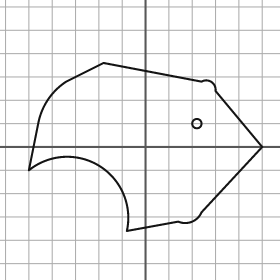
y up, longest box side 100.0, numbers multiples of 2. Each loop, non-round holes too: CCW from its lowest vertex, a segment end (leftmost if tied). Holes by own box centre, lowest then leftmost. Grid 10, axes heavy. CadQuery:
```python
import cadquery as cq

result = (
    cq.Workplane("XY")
    .moveTo(-8.0, -36.0)
    .lineTo(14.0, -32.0)
    .threePointArc((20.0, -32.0), (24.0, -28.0))
    .lineTo(50.0, 0.0)
    .lineTo(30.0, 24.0)
    .threePointArc((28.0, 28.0), (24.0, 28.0))
    .lineTo(-18.0, 36.0)
    .lineTo(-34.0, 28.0)
    .threePointArc((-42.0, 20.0), (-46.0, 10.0))
    .lineTo(-50.0, -10.0)
    .threePointArc((-20.0, -8.0), (-8.0, -36.0))
    .close()
    .moveTo(22.0, 10.0)
    .circle(2.0)
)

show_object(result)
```